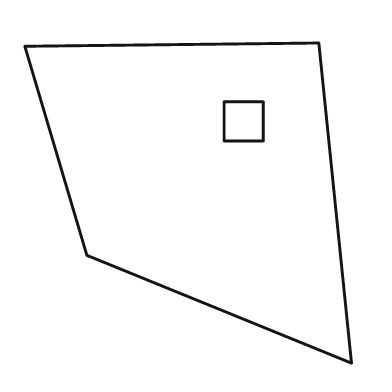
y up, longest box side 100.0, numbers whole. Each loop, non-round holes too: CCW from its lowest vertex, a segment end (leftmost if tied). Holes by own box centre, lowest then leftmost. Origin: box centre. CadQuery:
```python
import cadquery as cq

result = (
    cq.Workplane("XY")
    .moveTo(50.0, -49.0)
    .lineTo(40.0, 49.0)
    .lineTo(-50.0, 48.0)
    .lineTo(-31.0, -16.0)
    .close()
    .moveTo(11.0, 19.0)
    .lineTo(23.0, 19.0)
    .lineTo(23.0, 31.0)
    .lineTo(11.0, 31.0)
    .close()
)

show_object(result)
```